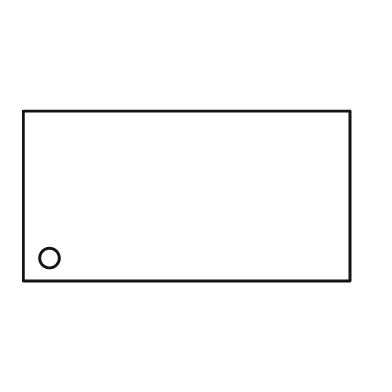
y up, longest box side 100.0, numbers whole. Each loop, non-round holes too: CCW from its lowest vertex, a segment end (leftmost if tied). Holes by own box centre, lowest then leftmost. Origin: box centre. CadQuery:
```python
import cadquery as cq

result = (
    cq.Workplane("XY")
    .moveTo(-50.0, -26.0)
    .lineTo(50.0, -26.0)
    .lineTo(50.0, 26.0)
    .lineTo(-50.0, 26.0)
    .close()
    .moveTo(-42.0, -19.0)
    .circle(3.0)
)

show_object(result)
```